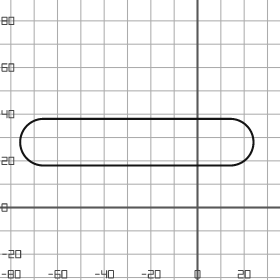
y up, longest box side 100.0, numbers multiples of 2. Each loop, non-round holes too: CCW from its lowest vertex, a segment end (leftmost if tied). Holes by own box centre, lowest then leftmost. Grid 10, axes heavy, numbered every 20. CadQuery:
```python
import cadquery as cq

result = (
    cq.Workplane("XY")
    .moveTo(-66.0, 18.0)
    .lineTo(14.0, 18.0)
    .threePointArc((24.0, 28.0), (14.0, 38.0))
    .lineTo(-66.0, 38.0)
    .threePointArc((-76.0, 28.0), (-66.0, 18.0))
    .close()
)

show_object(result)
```